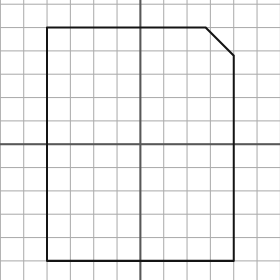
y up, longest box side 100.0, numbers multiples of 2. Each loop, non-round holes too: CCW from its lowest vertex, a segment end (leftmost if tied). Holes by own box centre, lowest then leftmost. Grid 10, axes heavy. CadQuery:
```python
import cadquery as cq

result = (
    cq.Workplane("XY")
    .moveTo(-40.0, -50.0)
    .lineTo(40.0, -50.0)
    .lineTo(40.0, 38.0)
    .lineTo(28.0, 50.0)
    .lineTo(-40.0, 50.0)
    .close()
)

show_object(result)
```